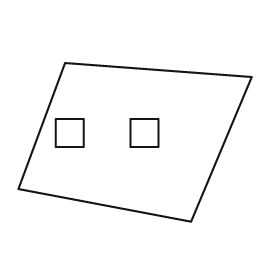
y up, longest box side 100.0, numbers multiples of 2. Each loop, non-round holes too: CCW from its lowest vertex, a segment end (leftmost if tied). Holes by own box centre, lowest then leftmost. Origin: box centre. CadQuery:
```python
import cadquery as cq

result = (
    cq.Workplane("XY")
    .moveTo(24.0, -34.0)
    .lineTo(50.0, 28.0)
    .lineTo(-30.0, 34.0)
    .lineTo(-50.0, -20.0)
    .close()
    .moveTo(-34.0, -2.0)
    .lineTo(-22.0, -2.0)
    .lineTo(-22.0, 10.0)
    .lineTo(-34.0, 10.0)
    .close()
    .moveTo(-2.0, -2.0)
    .lineTo(10.0, -2.0)
    .lineTo(10.0, 10.0)
    .lineTo(-2.0, 10.0)
    .close()
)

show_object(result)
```